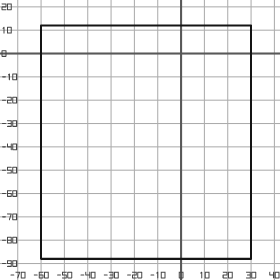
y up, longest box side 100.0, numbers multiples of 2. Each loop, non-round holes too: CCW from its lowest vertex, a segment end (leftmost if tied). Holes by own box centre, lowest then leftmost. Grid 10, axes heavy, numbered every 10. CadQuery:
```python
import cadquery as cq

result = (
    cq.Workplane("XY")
    .moveTo(-60.0, -88.0)
    .lineTo(30.0, -88.0)
    .lineTo(30.0, 12.0)
    .lineTo(-60.0, 12.0)
    .close()
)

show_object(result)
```